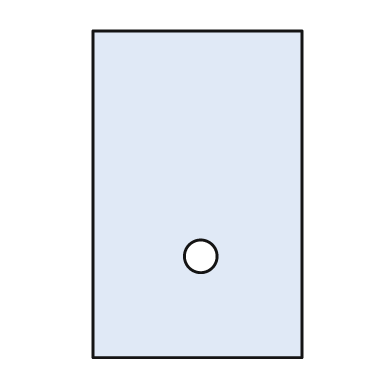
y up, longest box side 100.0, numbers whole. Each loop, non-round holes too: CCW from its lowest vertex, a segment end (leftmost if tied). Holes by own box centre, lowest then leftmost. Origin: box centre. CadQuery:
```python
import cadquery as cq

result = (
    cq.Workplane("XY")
    .moveTo(-32.0, -50.0)
    .lineTo(32.0, -50.0)
    .lineTo(32.0, 50.0)
    .lineTo(-32.0, 50.0)
    .close()
    .moveTo(1.0, -19.0)
    .circle(5.0)
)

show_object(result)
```